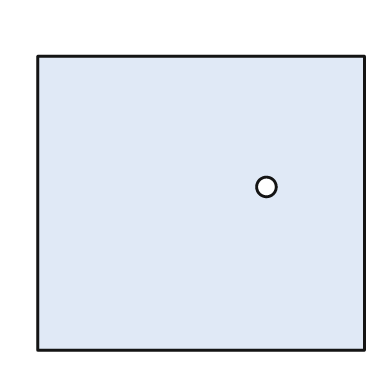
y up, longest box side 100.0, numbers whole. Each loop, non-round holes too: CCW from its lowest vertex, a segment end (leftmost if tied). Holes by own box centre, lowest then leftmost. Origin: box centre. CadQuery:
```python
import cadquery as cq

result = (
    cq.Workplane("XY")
    .moveTo(-50.0, -45.0)
    .lineTo(50.0, -45.0)
    .lineTo(50.0, 45.0)
    .lineTo(-50.0, 45.0)
    .close()
    .moveTo(20.0, 5.0)
    .circle(3.0)
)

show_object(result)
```